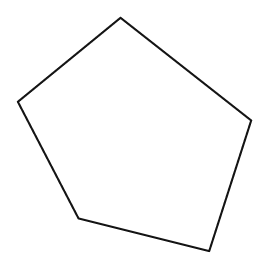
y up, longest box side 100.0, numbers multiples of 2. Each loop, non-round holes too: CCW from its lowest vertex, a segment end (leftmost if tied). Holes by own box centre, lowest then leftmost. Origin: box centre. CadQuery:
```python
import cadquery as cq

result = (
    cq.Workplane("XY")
    .moveTo(32.0, -50.0)
    .lineTo(50.0, 6.0)
    .lineTo(-6.0, 50.0)
    .lineTo(-50.0, 14.0)
    .lineTo(-24.0, -36.0)
    .close()
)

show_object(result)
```